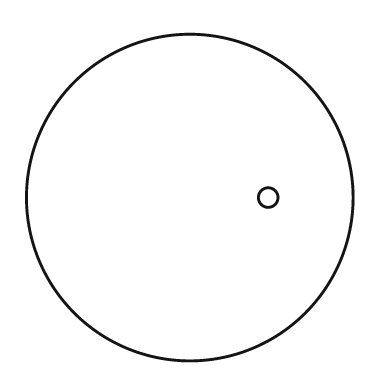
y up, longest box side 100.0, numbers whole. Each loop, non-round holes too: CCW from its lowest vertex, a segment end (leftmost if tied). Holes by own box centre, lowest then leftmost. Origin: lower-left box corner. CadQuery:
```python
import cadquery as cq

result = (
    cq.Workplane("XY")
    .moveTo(50.0, 50.0)
    .circle(50.0)
    .moveTo(74.0, 50.0)
    .circle(3.0)
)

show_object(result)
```